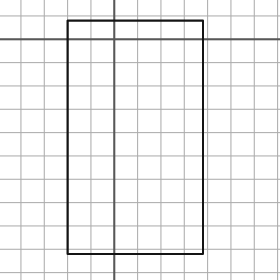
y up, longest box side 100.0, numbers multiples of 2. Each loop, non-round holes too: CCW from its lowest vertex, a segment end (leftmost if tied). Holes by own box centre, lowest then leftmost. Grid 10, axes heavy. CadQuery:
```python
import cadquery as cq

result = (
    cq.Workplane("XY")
    .moveTo(-20.0, -92.0)
    .lineTo(38.0, -92.0)
    .lineTo(38.0, 8.0)
    .lineTo(-20.0, 8.0)
    .close()
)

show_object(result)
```